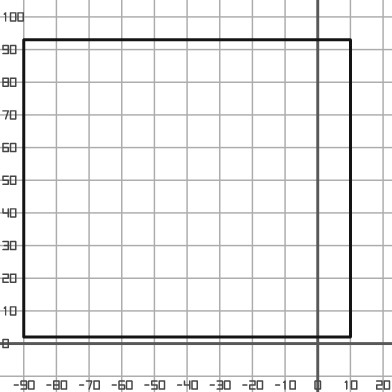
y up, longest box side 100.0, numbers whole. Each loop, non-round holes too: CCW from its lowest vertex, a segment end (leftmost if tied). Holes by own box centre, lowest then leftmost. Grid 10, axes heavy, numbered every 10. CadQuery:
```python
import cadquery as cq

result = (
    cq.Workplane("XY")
    .moveTo(-90.0, 2.0)
    .lineTo(10.0, 2.0)
    .lineTo(10.0, 93.0)
    .lineTo(-90.0, 93.0)
    .close()
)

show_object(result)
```